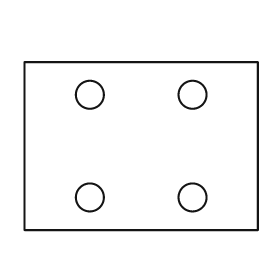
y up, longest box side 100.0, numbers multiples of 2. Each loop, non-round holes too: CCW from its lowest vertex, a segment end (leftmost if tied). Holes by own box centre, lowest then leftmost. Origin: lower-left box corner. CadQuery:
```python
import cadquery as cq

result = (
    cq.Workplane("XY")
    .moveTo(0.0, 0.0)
    .lineTo(100.0, 0.0)
    .lineTo(100.0, 72.0)
    .lineTo(0.0, 72.0)
    .close()
    .moveTo(28.0, 14.0)
    .circle(6.0)
    .moveTo(72.0, 14.0)
    .circle(6.0)
    .moveTo(28.0, 58.0)
    .circle(6.0)
    .moveTo(72.0, 58.0)
    .circle(6.0)
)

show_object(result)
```